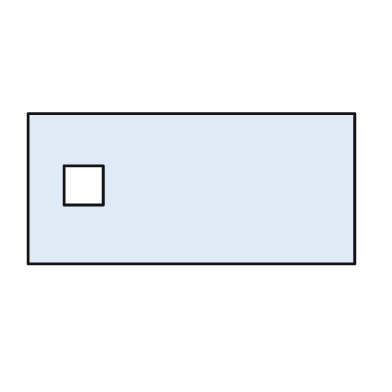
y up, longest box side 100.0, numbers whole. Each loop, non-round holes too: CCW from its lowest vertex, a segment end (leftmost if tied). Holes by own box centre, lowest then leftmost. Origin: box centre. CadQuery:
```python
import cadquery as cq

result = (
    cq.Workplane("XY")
    .moveTo(-50.0, -23.0)
    .lineTo(50.0, -23.0)
    .lineTo(50.0, 23.0)
    .lineTo(-50.0, 23.0)
    .close()
    .moveTo(-39.0, -5.0)
    .lineTo(-27.0, -5.0)
    .lineTo(-27.0, 7.0)
    .lineTo(-39.0, 7.0)
    .close()
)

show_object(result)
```